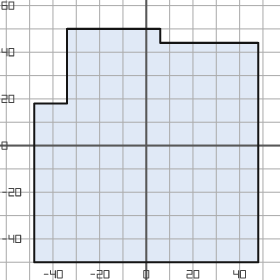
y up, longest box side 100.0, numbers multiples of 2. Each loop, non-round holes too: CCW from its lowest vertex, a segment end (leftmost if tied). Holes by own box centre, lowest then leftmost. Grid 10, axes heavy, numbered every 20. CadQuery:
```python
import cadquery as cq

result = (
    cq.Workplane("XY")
    .moveTo(-48.0, -50.0)
    .lineTo(48.0, -50.0)
    .lineTo(48.0, 44.0)
    .lineTo(6.0, 44.0)
    .lineTo(6.0, 50.0)
    .lineTo(-34.0, 50.0)
    .lineTo(-34.0, 18.0)
    .lineTo(-48.0, 18.0)
    .close()
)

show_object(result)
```